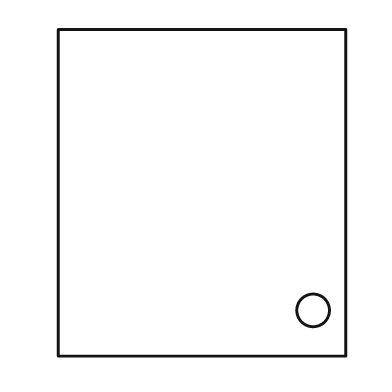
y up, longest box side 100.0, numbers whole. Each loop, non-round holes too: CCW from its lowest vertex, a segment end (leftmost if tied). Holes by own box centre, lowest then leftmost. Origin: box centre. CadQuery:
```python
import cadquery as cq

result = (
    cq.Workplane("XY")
    .moveTo(-44.0, -50.0)
    .lineTo(44.0, -50.0)
    .lineTo(44.0, 50.0)
    .lineTo(-44.0, 50.0)
    .close()
    .moveTo(34.0, -36.0)
    .circle(5.0)
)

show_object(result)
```